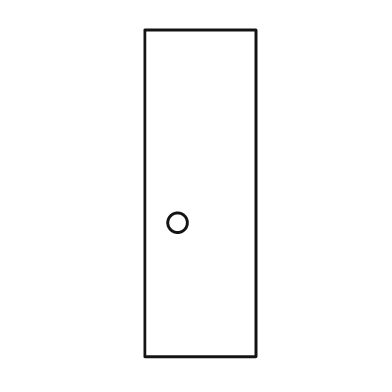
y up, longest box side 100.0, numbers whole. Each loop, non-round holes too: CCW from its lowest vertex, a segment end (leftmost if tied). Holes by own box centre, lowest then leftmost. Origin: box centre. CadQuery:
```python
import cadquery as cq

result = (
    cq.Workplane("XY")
    .moveTo(-17.0, -50.0)
    .lineTo(17.0, -50.0)
    .lineTo(17.0, 50.0)
    .lineTo(-17.0, 50.0)
    .close()
    .moveTo(-7.0, -9.0)
    .circle(3.0)
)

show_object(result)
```